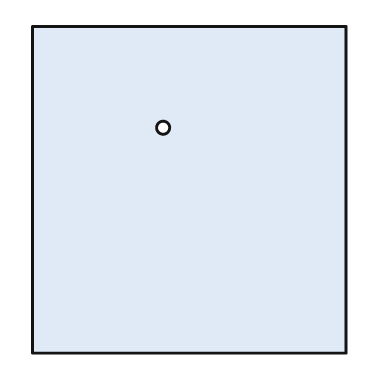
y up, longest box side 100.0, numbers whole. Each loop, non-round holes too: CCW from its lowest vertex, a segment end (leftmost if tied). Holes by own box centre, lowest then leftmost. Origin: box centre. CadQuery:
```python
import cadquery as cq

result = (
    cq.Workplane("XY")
    .moveTo(-48.0, -50.0)
    .lineTo(48.0, -50.0)
    .lineTo(48.0, 50.0)
    .lineTo(-48.0, 50.0)
    .close()
    .moveTo(-8.0, 19.0)
    .circle(2.0)
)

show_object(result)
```